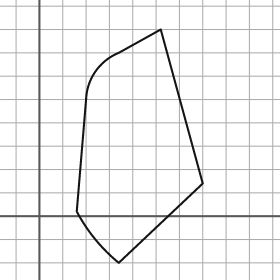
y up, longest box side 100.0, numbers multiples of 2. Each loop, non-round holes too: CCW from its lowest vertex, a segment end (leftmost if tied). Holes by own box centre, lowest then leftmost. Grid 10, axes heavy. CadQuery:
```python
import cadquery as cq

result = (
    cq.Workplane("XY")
    .moveTo(34.0, -20.0)
    .lineTo(70.0, 14.0)
    .lineTo(52.0, 80.0)
    .lineTo(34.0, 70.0)
    .threePointArc((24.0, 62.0), (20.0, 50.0))
    .lineTo(16.0, 2.0)
    .threePointArc((24.0, -10.0), (34.0, -20.0))
    .close()
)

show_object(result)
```